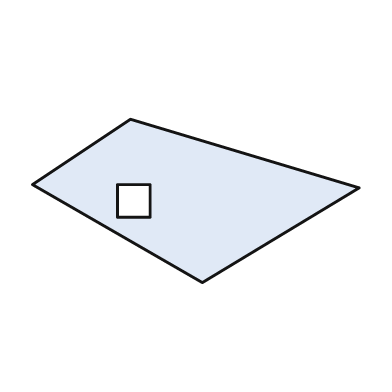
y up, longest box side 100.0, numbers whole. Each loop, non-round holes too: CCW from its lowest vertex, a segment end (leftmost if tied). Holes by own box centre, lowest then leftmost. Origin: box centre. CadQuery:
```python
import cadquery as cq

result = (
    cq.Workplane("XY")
    .moveTo(2.0, -25.0)
    .lineTo(50.0, 4.0)
    .lineTo(-20.0, 25.0)
    .lineTo(-50.0, 5.0)
    .close()
    .moveTo(-24.0, -5.0)
    .lineTo(-14.0, -5.0)
    .lineTo(-14.0, 5.0)
    .lineTo(-24.0, 5.0)
    .close()
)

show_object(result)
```